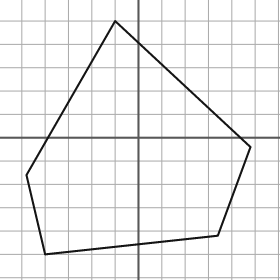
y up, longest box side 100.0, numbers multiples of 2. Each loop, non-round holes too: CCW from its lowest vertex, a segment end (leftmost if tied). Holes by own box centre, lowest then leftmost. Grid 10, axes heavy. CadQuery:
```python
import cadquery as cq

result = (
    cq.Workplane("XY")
    .moveTo(-40.0, -50.0)
    .lineTo(34.0, -42.0)
    .lineTo(48.0, -4.0)
    .lineTo(-10.0, 50.0)
    .lineTo(-48.0, -16.0)
    .close()
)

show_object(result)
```